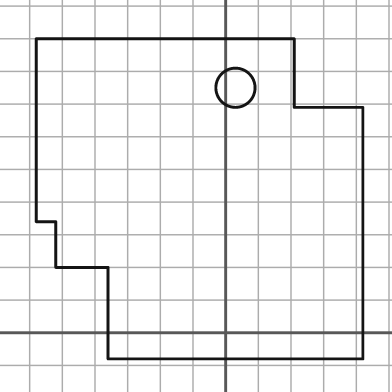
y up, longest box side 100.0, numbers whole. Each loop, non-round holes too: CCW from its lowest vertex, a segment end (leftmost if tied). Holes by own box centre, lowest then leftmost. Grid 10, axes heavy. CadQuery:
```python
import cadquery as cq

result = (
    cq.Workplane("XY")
    .moveTo(-36.0, -8.0)
    .lineTo(42.0, -8.0)
    .lineTo(42.0, 69.0)
    .lineTo(21.0, 69.0)
    .lineTo(21.0, 90.0)
    .lineTo(-58.0, 90.0)
    .lineTo(-58.0, 34.0)
    .lineTo(-52.0, 34.0)
    .lineTo(-52.0, 20.0)
    .lineTo(-36.0, 20.0)
    .close()
    .moveTo(3.0, 75.0)
    .circle(6.0)
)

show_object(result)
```